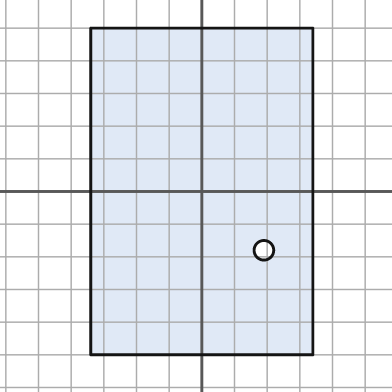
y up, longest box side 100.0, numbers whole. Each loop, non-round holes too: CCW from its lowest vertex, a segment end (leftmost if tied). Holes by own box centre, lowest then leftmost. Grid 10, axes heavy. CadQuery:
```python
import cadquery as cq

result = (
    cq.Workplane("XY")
    .moveTo(-34.0, -50.0)
    .lineTo(34.0, -50.0)
    .lineTo(34.0, 50.0)
    .lineTo(-34.0, 50.0)
    .close()
    .moveTo(19.0, -18.0)
    .circle(3.0)
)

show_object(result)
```